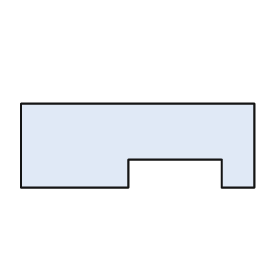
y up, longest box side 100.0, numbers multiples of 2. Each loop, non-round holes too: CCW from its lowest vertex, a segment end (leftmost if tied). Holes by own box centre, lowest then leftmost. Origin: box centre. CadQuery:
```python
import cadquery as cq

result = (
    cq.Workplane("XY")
    .moveTo(-50.0, -18.0)
    .lineTo(-4.0, -18.0)
    .lineTo(-4.0, -6.0)
    .lineTo(36.0, -6.0)
    .lineTo(36.0, -18.0)
    .lineTo(50.0, -18.0)
    .lineTo(50.0, 18.0)
    .lineTo(-50.0, 18.0)
    .close()
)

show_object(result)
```